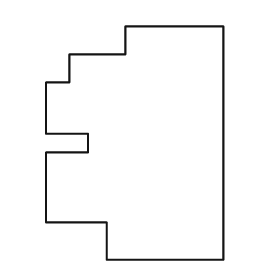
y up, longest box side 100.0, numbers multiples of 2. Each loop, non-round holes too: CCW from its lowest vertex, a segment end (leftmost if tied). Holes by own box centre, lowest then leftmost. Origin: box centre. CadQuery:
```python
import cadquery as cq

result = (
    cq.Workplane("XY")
    .moveTo(-12.0, -50.0)
    .lineTo(38.0, -50.0)
    .lineTo(38.0, 50.0)
    .lineTo(-4.0, 50.0)
    .lineTo(-4.0, 38.0)
    .lineTo(-28.0, 38.0)
    .lineTo(-28.0, 26.0)
    .lineTo(-38.0, 26.0)
    .lineTo(-38.0, 4.0)
    .lineTo(-20.0, 4.0)
    .lineTo(-20.0, -4.0)
    .lineTo(-38.0, -4.0)
    .lineTo(-38.0, -34.0)
    .lineTo(-12.0, -34.0)
    .close()
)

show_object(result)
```